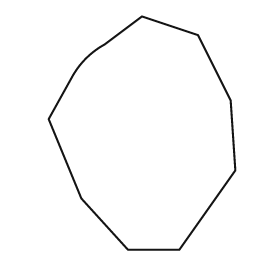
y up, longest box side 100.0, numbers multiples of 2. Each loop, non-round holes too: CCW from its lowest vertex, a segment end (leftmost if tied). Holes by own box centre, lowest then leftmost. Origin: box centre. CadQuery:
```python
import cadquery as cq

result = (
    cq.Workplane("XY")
    .moveTo(-6.0, -50.0)
    .lineTo(16.0, -50.0)
    .lineTo(40.0, -16.0)
    .lineTo(38.0, 14.0)
    .lineTo(24.0, 42.0)
    .lineTo(0.0, 50.0)
    .lineTo(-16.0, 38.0)
    .threePointArc((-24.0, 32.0), (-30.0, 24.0))
    .lineTo(-40.0, 6.0)
    .lineTo(-26.0, -28.0)
    .close()
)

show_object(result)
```